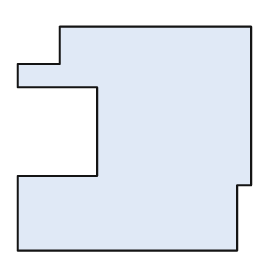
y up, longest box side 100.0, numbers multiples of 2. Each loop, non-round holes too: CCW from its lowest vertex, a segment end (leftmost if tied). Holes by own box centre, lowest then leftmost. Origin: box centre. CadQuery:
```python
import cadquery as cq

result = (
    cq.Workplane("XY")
    .moveTo(-50.0, -48.0)
    .lineTo(44.0, -48.0)
    .lineTo(44.0, -20.0)
    .lineTo(50.0, -20.0)
    .lineTo(50.0, 48.0)
    .lineTo(-32.0, 48.0)
    .lineTo(-32.0, 32.0)
    .lineTo(-50.0, 32.0)
    .lineTo(-50.0, 22.0)
    .lineTo(-16.0, 22.0)
    .lineTo(-16.0, -16.0)
    .lineTo(-50.0, -16.0)
    .close()
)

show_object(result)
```